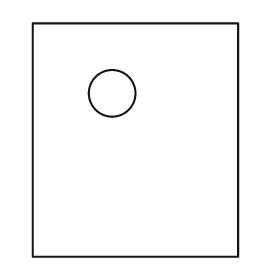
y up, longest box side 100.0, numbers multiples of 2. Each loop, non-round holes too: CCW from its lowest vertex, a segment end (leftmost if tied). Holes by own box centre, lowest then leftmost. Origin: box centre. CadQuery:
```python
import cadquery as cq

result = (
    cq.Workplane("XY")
    .moveTo(-44.0, -50.0)
    .lineTo(44.0, -50.0)
    .lineTo(44.0, 50.0)
    .lineTo(-44.0, 50.0)
    .close()
    .moveTo(-10.0, 20.0)
    .circle(10.0)
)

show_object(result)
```